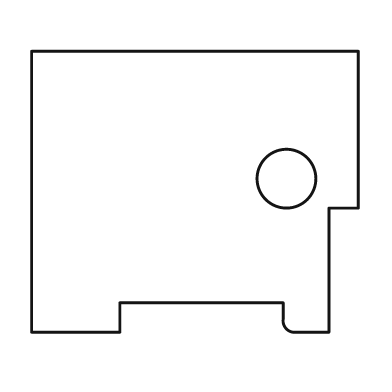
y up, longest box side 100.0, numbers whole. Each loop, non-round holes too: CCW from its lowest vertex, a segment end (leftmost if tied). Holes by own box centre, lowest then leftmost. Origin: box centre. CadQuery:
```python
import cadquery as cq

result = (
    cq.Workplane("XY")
    .moveTo(-50.0, -43.0)
    .lineTo(-23.0, -43.0)
    .lineTo(-23.0, -34.0)
    .lineTo(27.0, -34.0)
    .lineTo(27.0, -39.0)
    .threePointArc((28.0, -42.0), (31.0, -43.0))
    .lineTo(41.0, -43.0)
    .lineTo(41.0, -5.0)
    .lineTo(50.0, -5.0)
    .lineTo(50.0, 43.0)
    .lineTo(-50.0, 43.0)
    .close()
    .moveTo(28.0, 4.0)
    .circle(9.0)
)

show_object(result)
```